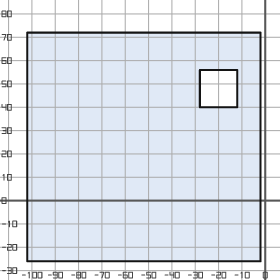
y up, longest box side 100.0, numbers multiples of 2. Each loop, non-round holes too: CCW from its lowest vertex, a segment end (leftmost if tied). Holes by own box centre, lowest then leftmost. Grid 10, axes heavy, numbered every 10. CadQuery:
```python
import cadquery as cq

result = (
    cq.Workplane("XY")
    .moveTo(-102.0, -26.0)
    .lineTo(-2.0, -26.0)
    .lineTo(-2.0, 72.0)
    .lineTo(-102.0, 72.0)
    .close()
    .moveTo(-28.0, 40.0)
    .lineTo(-12.0, 40.0)
    .lineTo(-12.0, 56.0)
    .lineTo(-28.0, 56.0)
    .close()
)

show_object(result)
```